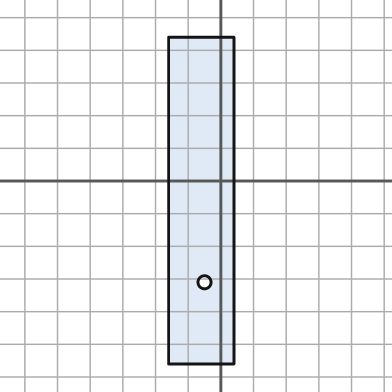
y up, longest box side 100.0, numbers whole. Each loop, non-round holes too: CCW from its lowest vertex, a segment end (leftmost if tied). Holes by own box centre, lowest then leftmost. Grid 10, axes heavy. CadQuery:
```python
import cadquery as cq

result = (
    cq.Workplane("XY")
    .moveTo(-16.0, -56.0)
    .lineTo(4.0, -56.0)
    .lineTo(4.0, 44.0)
    .lineTo(-16.0, 44.0)
    .close()
    .moveTo(-5.0, -31.0)
    .circle(2.0)
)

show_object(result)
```